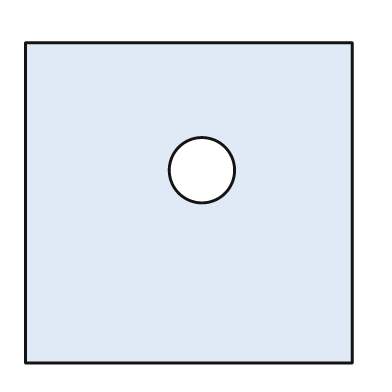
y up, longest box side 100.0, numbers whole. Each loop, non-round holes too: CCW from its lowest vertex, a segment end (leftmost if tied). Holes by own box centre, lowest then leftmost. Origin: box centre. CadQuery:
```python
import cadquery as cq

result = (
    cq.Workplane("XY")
    .moveTo(-50.0, -49.0)
    .lineTo(50.0, -49.0)
    .lineTo(50.0, 49.0)
    .lineTo(-50.0, 49.0)
    .close()
    .moveTo(4.0, 10.0)
    .circle(10.0)
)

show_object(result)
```